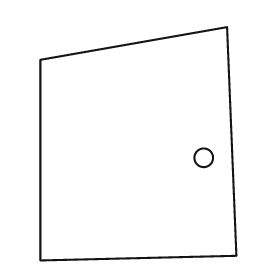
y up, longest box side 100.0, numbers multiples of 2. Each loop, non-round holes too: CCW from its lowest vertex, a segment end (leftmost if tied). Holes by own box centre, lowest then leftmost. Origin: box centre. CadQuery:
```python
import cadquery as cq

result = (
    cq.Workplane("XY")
    .moveTo(-42.0, -50.0)
    .lineTo(42.0, -48.0)
    .lineTo(38.0, 50.0)
    .lineTo(-42.0, 36.0)
    .close()
    .moveTo(28.0, -6.0)
    .circle(4.0)
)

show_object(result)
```